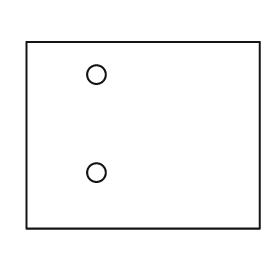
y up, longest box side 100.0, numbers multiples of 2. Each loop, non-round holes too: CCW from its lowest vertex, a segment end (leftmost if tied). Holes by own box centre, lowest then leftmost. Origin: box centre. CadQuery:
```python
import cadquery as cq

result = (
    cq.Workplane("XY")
    .moveTo(-50.0, -40.0)
    .lineTo(50.0, -40.0)
    .lineTo(50.0, 40.0)
    .lineTo(-50.0, 40.0)
    .close()
    .moveTo(-20.0, -16.0)
    .circle(4.0)
    .moveTo(-20.0, 26.0)
    .circle(4.0)
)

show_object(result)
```